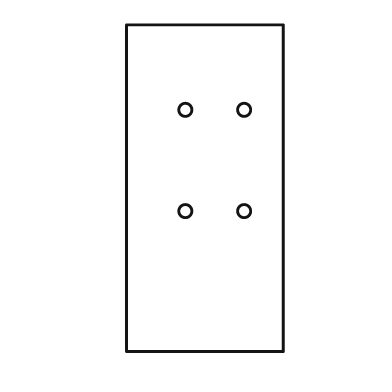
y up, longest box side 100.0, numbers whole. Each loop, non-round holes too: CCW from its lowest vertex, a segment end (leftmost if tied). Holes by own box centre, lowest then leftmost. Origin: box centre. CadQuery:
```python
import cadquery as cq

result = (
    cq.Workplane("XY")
    .moveTo(-24.0, -50.0)
    .lineTo(24.0, -50.0)
    .lineTo(24.0, 50.0)
    .lineTo(-24.0, 50.0)
    .close()
    .moveTo(-6.0, -7.0)
    .circle(2.0)
    .moveTo(12.0, -7.0)
    .circle(2.0)
    .moveTo(-6.0, 24.0)
    .circle(2.0)
    .moveTo(12.0, 24.0)
    .circle(2.0)
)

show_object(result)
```